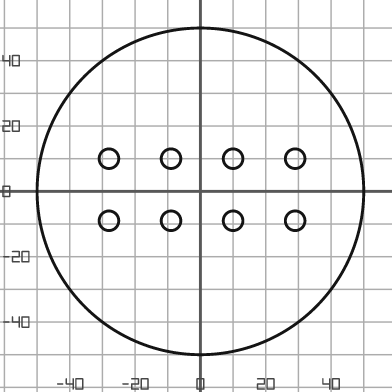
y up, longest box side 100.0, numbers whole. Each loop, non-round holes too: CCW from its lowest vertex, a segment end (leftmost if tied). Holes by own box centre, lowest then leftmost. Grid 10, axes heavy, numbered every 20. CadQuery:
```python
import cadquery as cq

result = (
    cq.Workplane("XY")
    .moveTo(0.0, 0.0)
    .circle(50.0)
    .moveTo(-28.0, -9.0)
    .circle(3.0)
    .moveTo(-9.0, -9.0)
    .circle(3.0)
    .moveTo(10.0, -9.0)
    .circle(3.0)
    .moveTo(29.0, -9.0)
    .circle(3.0)
    .moveTo(-28.0, 10.0)
    .circle(3.0)
    .moveTo(-9.0, 10.0)
    .circle(3.0)
    .moveTo(10.0, 10.0)
    .circle(3.0)
    .moveTo(29.0, 10.0)
    .circle(3.0)
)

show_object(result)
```